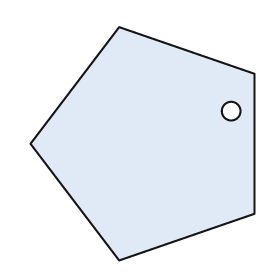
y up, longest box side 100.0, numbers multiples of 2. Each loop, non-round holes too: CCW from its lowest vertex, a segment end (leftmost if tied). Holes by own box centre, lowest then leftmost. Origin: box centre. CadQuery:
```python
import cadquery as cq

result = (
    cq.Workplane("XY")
    .moveTo(-10.0, -50.0)
    .lineTo(48.0, -30.0)
    .lineTo(48.0, 30.0)
    .lineTo(-10.0, 50.0)
    .lineTo(-48.0, 0.0)
    .close()
    .moveTo(38.0, 14.0)
    .circle(4.0)
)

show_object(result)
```